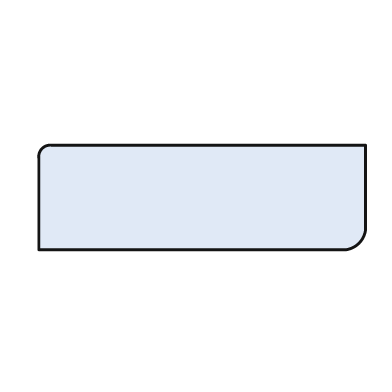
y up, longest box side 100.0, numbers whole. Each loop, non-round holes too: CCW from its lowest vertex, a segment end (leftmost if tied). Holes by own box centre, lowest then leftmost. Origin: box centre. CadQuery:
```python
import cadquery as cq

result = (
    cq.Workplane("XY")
    .moveTo(-50.0, -16.0)
    .lineTo(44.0, -16.0)
    .threePointArc((48.0, -14.0), (50.0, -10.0))
    .lineTo(50.0, 16.0)
    .lineTo(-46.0, 16.0)
    .threePointArc((-49.0, 15.0), (-50.0, 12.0))
    .close()
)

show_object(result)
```